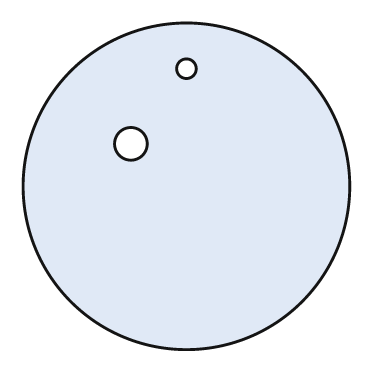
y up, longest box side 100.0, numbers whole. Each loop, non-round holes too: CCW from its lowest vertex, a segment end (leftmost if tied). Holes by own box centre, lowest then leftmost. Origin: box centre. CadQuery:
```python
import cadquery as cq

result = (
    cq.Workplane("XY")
    .moveTo(0.0, 0.0)
    .circle(50.0)
    .moveTo(-17.0, 13.0)
    .circle(5.0)
    .moveTo(0.0, 36.0)
    .circle(3.0)
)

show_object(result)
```